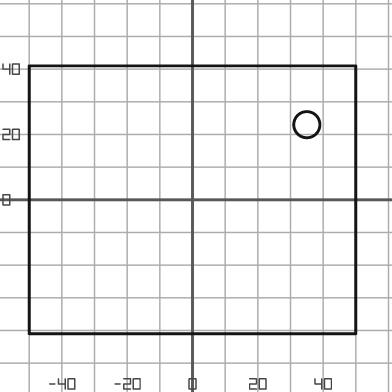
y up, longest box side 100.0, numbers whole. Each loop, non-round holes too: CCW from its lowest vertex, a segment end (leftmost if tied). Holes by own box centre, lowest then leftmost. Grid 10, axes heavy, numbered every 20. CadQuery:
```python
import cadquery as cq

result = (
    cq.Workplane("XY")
    .moveTo(-50.0, -41.0)
    .lineTo(50.0, -41.0)
    .lineTo(50.0, 41.0)
    .lineTo(-50.0, 41.0)
    .close()
    .moveTo(35.0, 23.0)
    .circle(4.0)
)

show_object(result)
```